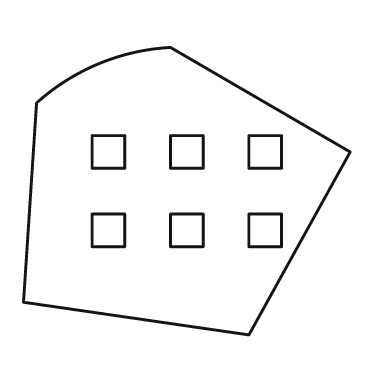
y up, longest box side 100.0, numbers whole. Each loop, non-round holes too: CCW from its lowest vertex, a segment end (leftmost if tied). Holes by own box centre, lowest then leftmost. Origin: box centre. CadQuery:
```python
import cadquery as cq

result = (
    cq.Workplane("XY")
    .moveTo(19.0, -44.0)
    .lineTo(50.0, 12.0)
    .lineTo(-5.0, 44.0)
    .threePointArc((-27.0, 39.0), (-46.0, 27.0))
    .lineTo(-50.0, -34.0)
    .close()
    .moveTo(-29.0, -17.0)
    .lineTo(-19.0, -17.0)
    .lineTo(-19.0, -7.0)
    .lineTo(-29.0, -7.0)
    .close()
    .moveTo(-5.0, -17.0)
    .lineTo(5.0, -17.0)
    .lineTo(5.0, -7.0)
    .lineTo(-5.0, -7.0)
    .close()
    .moveTo(19.0, -17.0)
    .lineTo(29.0, -17.0)
    .lineTo(29.0, -7.0)
    .lineTo(19.0, -7.0)
    .close()
    .moveTo(-29.0, 7.0)
    .lineTo(-19.0, 7.0)
    .lineTo(-19.0, 17.0)
    .lineTo(-29.0, 17.0)
    .close()
    .moveTo(-5.0, 7.0)
    .lineTo(5.0, 7.0)
    .lineTo(5.0, 17.0)
    .lineTo(-5.0, 17.0)
    .close()
    .moveTo(19.0, 7.0)
    .lineTo(29.0, 7.0)
    .lineTo(29.0, 17.0)
    .lineTo(19.0, 17.0)
    .close()
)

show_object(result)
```